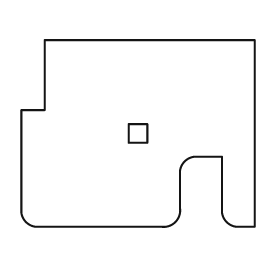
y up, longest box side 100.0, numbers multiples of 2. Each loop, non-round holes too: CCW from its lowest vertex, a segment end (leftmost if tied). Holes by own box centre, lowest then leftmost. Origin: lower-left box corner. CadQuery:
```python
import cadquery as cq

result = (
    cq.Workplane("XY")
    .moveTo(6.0, 0.0)
    .lineTo(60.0, 0.0)
    .threePointArc((66.0, 2.0), (68.0, 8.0))
    .lineTo(68.0, 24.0)
    .threePointArc((70.0, 28.0), (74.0, 30.0))
    .lineTo(86.0, 30.0)
    .lineTo(86.0, 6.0)
    .threePointArc((88.0, 2.0), (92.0, 0.0))
    .lineTo(100.0, 0.0)
    .lineTo(100.0, 80.0)
    .lineTo(10.0, 80.0)
    .lineTo(10.0, 50.0)
    .lineTo(0.0, 50.0)
    .lineTo(0.0, 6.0)
    .threePointArc((2.0, 2.0), (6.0, 0.0))
    .close()
    .moveTo(46.0, 36.0)
    .lineTo(54.0, 36.0)
    .lineTo(54.0, 44.0)
    .lineTo(46.0, 44.0)
    .close()
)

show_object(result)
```